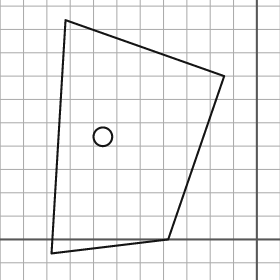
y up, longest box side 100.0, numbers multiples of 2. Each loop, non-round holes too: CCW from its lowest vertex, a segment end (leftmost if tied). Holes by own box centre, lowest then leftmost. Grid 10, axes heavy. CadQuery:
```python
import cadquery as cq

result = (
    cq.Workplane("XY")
    .moveTo(-88.0, -6.0)
    .lineTo(-38.0, 0.0)
    .lineTo(-14.0, 70.0)
    .lineTo(-82.0, 94.0)
    .close()
    .moveTo(-66.0, 44.0)
    .circle(4.0)
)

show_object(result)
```